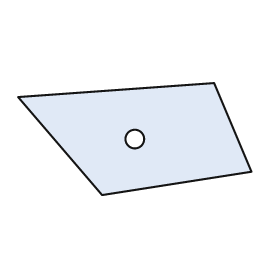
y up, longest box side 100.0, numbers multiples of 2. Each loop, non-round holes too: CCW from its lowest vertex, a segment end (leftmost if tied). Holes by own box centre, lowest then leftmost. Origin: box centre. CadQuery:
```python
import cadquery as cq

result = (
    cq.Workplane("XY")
    .moveTo(-14.0, -24.0)
    .lineTo(50.0, -14.0)
    .lineTo(34.0, 24.0)
    .lineTo(-50.0, 18.0)
    .close()
    .moveTo(0.0, 0.0)
    .circle(4.0)
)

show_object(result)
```